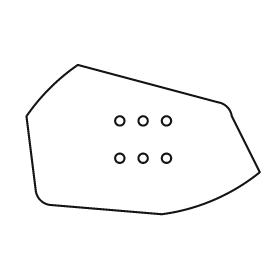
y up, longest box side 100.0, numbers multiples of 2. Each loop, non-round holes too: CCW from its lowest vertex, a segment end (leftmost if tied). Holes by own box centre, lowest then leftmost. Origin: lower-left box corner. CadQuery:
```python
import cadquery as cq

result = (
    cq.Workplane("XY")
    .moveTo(58.0, 0.0)
    .threePointArc((80.0, 6.0), (100.0, 18.0))
    .lineTo(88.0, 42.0)
    .threePointArc((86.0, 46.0), (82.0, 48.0))
    .lineTo(22.0, 64.0)
    .threePointArc((10.0, 54.0), (0.0, 42.0))
    .lineTo(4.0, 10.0)
    .threePointArc((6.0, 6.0), (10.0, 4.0))
    .close()
    .moveTo(40.0, 24.0)
    .circle(2.0)
    .moveTo(50.0, 24.0)
    .circle(2.0)
    .moveTo(60.0, 24.0)
    .circle(2.0)
    .moveTo(40.0, 40.0)
    .circle(2.0)
    .moveTo(50.0, 40.0)
    .circle(2.0)
    .moveTo(60.0, 40.0)
    .circle(2.0)
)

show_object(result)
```